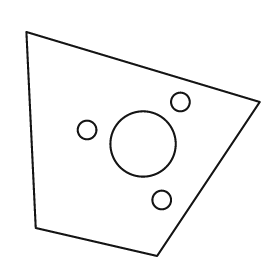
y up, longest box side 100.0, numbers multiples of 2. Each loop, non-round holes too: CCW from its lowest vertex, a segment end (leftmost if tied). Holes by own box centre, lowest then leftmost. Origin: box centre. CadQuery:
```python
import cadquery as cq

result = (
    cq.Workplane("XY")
    .moveTo(6.0, -48.0)
    .lineTo(50.0, 18.0)
    .lineTo(-50.0, 48.0)
    .lineTo(-46.0, -36.0)
    .close()
    .moveTo(8.0, -24.0)
    .circle(4.0)
    .moveTo(0.0, 0.0)
    .circle(14.0)
    .moveTo(-24.0, 6.0)
    .circle(4.0)
    .moveTo(16.0, 18.0)
    .circle(4.0)
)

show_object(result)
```